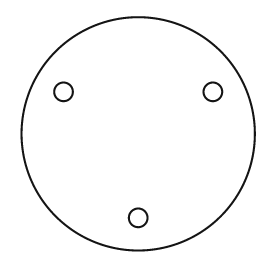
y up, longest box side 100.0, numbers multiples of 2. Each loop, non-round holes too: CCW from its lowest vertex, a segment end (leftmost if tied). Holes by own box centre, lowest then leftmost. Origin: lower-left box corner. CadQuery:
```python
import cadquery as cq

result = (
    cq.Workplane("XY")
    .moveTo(50.0, 50.0)
    .circle(50.0)
    .moveTo(50.0, 14.0)
    .circle(4.0)
    .moveTo(18.0, 68.0)
    .circle(4.0)
    .moveTo(82.0, 68.0)
    .circle(4.0)
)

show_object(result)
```